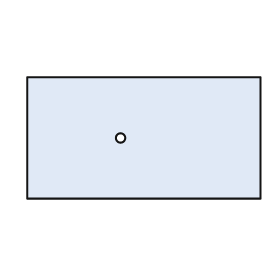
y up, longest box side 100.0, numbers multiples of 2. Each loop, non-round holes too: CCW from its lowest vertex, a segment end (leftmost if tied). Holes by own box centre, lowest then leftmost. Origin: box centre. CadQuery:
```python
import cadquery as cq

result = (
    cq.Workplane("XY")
    .moveTo(-50.0, -26.0)
    .lineTo(50.0, -26.0)
    .lineTo(50.0, 26.0)
    .lineTo(-50.0, 26.0)
    .close()
    .moveTo(-10.0, 0.0)
    .circle(2.0)
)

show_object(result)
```